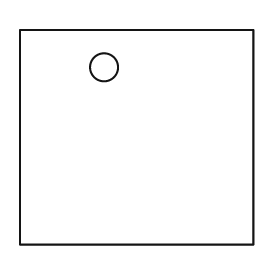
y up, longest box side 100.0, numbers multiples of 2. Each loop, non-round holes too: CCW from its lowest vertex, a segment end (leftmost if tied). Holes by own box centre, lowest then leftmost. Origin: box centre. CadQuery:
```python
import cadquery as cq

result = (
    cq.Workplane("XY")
    .moveTo(-50.0, -46.0)
    .lineTo(50.0, -46.0)
    .lineTo(50.0, 46.0)
    .lineTo(-50.0, 46.0)
    .close()
    .moveTo(-14.0, 30.0)
    .circle(6.0)
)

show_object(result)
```